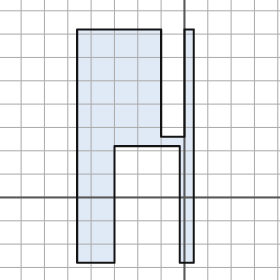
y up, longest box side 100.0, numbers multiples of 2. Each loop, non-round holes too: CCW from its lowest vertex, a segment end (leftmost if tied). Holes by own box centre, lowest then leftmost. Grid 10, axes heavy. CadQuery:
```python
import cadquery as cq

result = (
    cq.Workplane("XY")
    .moveTo(-46.0, -28.0)
    .lineTo(-30.0, -28.0)
    .lineTo(-30.0, 22.0)
    .lineTo(-2.0, 22.0)
    .lineTo(-2.0, -28.0)
    .lineTo(4.0, -28.0)
    .lineTo(4.0, 72.0)
    .lineTo(0.0, 72.0)
    .lineTo(0.0, 26.0)
    .lineTo(-10.0, 26.0)
    .lineTo(-10.0, 72.0)
    .lineTo(-46.0, 72.0)
    .close()
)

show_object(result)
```